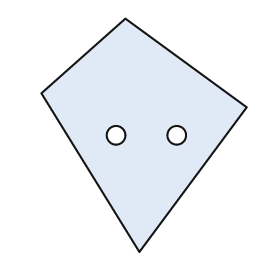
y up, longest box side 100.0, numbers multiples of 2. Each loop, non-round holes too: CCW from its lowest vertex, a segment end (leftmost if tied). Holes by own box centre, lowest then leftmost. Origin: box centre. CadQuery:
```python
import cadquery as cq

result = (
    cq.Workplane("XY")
    .moveTo(-2.0, -50.0)
    .lineTo(44.0, 12.0)
    .lineTo(-8.0, 50.0)
    .lineTo(-44.0, 18.0)
    .close()
    .moveTo(-12.0, 0.0)
    .circle(4.0)
    .moveTo(14.0, 0.0)
    .circle(4.0)
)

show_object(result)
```